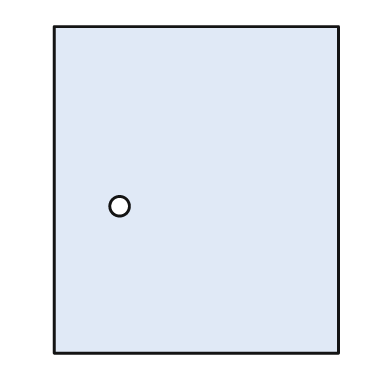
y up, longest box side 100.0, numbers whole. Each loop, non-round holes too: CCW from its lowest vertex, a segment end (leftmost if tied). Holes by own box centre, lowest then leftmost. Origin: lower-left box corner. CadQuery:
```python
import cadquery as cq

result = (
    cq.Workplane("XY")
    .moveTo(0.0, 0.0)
    .lineTo(87.0, 0.0)
    .lineTo(87.0, 100.0)
    .lineTo(0.0, 100.0)
    .close()
    .moveTo(20.0, 45.0)
    .circle(3.0)
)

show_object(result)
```